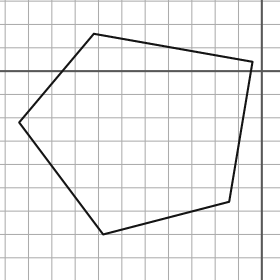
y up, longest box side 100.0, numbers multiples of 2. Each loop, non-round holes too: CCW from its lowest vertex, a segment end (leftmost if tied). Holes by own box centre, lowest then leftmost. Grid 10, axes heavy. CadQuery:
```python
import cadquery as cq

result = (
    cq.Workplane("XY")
    .moveTo(-68.0, -70.0)
    .lineTo(-14.0, -56.0)
    .lineTo(-4.0, 4.0)
    .lineTo(-72.0, 16.0)
    .lineTo(-104.0, -22.0)
    .close()
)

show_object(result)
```